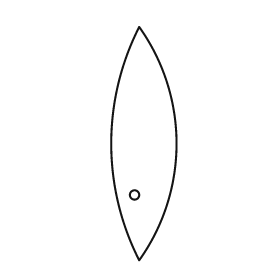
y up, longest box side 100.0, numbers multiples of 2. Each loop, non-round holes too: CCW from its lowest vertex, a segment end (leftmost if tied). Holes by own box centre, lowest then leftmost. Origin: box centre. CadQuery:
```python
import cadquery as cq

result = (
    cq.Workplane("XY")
    .moveTo(-2.0, -50.0)
    .threePointArc((14.0, 0.0), (-2.0, 50.0))
    .threePointArc((-14.0, 0.0), (-2.0, -50.0))
    .close()
    .moveTo(-4.0, -22.0)
    .circle(2.0)
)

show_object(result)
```